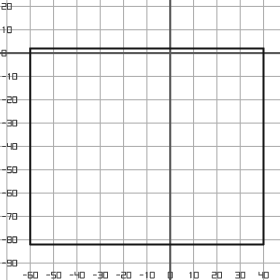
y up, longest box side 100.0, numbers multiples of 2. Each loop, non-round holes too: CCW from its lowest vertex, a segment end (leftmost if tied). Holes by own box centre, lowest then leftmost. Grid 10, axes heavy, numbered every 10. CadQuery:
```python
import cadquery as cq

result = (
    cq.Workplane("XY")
    .moveTo(-60.0, -82.0)
    .lineTo(40.0, -82.0)
    .lineTo(40.0, 2.0)
    .lineTo(-60.0, 2.0)
    .close()
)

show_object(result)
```